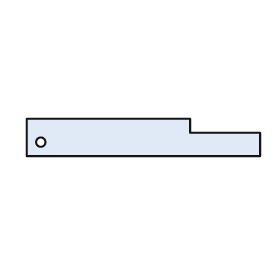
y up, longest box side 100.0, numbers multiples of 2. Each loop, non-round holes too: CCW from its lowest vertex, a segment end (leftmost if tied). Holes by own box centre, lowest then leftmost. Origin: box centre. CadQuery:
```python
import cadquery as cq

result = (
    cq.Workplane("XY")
    .moveTo(-50.0, -8.0)
    .lineTo(50.0, -8.0)
    .lineTo(50.0, 2.0)
    .lineTo(20.0, 2.0)
    .lineTo(20.0, 8.0)
    .lineTo(-50.0, 8.0)
    .close()
    .moveTo(-44.0, -2.0)
    .circle(2.0)
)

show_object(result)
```